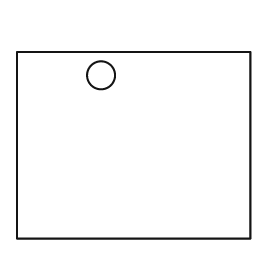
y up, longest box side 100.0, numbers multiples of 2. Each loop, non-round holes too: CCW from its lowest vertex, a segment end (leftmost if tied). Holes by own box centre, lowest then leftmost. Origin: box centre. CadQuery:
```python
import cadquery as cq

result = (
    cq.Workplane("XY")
    .moveTo(-50.0, -40.0)
    .lineTo(50.0, -40.0)
    .lineTo(50.0, 40.0)
    .lineTo(-50.0, 40.0)
    .close()
    .moveTo(-14.0, 30.0)
    .circle(6.0)
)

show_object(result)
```